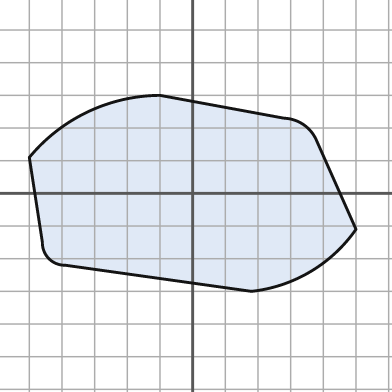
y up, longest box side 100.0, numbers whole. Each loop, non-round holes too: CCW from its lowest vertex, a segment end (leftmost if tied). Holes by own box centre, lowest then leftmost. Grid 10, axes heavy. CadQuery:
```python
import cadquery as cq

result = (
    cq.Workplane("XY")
    .moveTo(18.0, -30.0)
    .threePointArc((36.0, -24.0), (50.0, -11.0))
    .lineTo(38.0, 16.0)
    .threePointArc((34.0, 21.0), (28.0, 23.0))
    .lineTo(-10.0, 30.0)
    .threePointArc((-32.0, 25.0), (-50.0, 11.0))
    .lineTo(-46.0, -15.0)
    .threePointArc((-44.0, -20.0), (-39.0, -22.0))
    .close()
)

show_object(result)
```